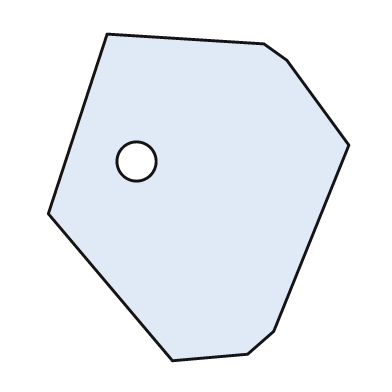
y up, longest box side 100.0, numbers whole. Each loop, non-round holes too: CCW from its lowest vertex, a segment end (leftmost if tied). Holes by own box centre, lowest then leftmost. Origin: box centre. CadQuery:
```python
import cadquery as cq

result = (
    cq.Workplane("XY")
    .moveTo(-8.0, -50.0)
    .lineTo(15.0, -48.0)
    .lineTo(23.0, -41.0)
    .lineTo(46.0, 16.0)
    .lineTo(27.0, 42.0)
    .lineTo(20.0, 47.0)
    .lineTo(-28.0, 50.0)
    .lineTo(-46.0, -5.0)
    .close()
    .moveTo(-19.0, 11.0)
    .circle(6.0)
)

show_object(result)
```